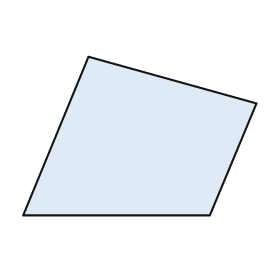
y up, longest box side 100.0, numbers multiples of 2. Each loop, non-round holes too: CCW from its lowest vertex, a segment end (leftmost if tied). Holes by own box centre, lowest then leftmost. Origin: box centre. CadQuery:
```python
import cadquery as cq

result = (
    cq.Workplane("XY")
    .moveTo(-50.0, -34.0)
    .lineTo(30.0, -34.0)
    .lineTo(50.0, 14.0)
    .lineTo(-22.0, 34.0)
    .close()
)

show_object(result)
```